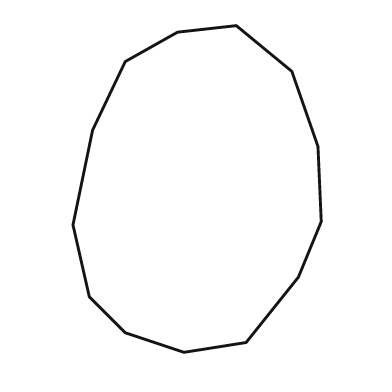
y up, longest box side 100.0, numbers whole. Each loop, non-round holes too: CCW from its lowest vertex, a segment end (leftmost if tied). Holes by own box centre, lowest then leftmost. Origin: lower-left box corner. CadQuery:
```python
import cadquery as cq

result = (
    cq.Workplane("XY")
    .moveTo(34.0, 0.0)
    .lineTo(53.0, 3.0)
    .lineTo(69.0, 23.0)
    .lineTo(76.0, 40.0)
    .lineTo(75.0, 63.0)
    .lineTo(67.0, 86.0)
    .lineTo(50.0, 100.0)
    .lineTo(32.0, 98.0)
    .lineTo(16.0, 89.0)
    .lineTo(6.0, 68.0)
    .lineTo(0.0, 39.0)
    .lineTo(5.0, 17.0)
    .lineTo(16.0, 6.0)
    .close()
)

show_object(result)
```